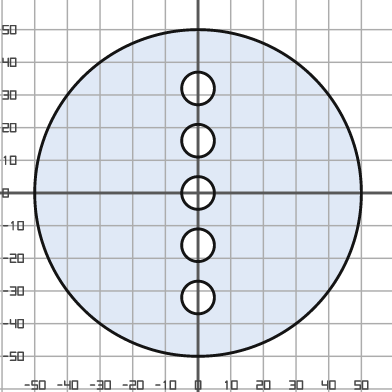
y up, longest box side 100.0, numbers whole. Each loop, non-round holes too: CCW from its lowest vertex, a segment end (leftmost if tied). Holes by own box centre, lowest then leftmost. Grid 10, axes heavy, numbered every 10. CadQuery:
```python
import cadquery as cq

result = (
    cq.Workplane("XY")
    .moveTo(0.0, 0.0)
    .circle(50.0)
    .moveTo(0.0, -32.0)
    .circle(5.0)
    .moveTo(0.0, -16.0)
    .circle(5.0)
    .moveTo(0.0, 0.0)
    .circle(5.0)
    .moveTo(0.0, 16.0)
    .circle(5.0)
    .moveTo(0.0, 32.0)
    .circle(5.0)
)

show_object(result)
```